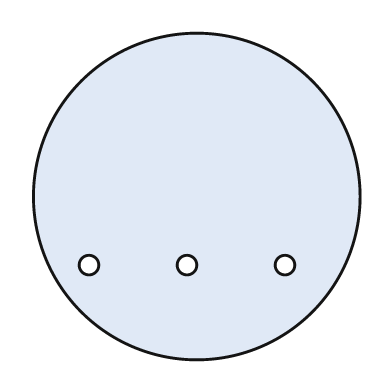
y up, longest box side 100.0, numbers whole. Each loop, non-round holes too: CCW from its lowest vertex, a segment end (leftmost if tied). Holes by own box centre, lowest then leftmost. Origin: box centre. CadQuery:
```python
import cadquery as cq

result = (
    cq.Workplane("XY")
    .moveTo(0.0, 0.0)
    .circle(50.0)
    .moveTo(-33.0, -21.0)
    .circle(3.0)
    .moveTo(-3.0, -21.0)
    .circle(3.0)
    .moveTo(27.0, -21.0)
    .circle(3.0)
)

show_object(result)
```